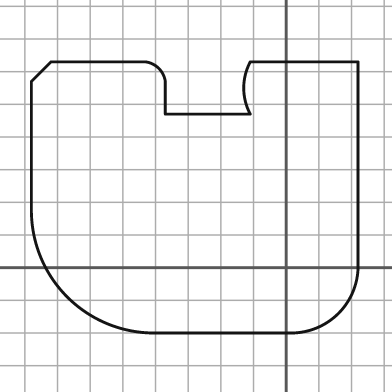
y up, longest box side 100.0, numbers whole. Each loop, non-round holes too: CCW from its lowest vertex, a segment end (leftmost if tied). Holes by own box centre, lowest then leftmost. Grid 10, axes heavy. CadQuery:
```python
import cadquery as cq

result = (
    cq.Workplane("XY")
    .moveTo(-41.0, -20.0)
    .lineTo(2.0, -20.0)
    .threePointArc((16.0, -14.0), (22.0, 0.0))
    .lineTo(22.0, 63.0)
    .lineTo(-11.0, 63.0)
    .threePointArc((-13.0, 55.0), (-11.0, 47.0))
    .lineTo(-37.0, 47.0)
    .lineTo(-37.0, 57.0)
    .threePointArc((-39.0, 61.0), (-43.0, 63.0))
    .lineTo(-72.0, 63.0)
    .lineTo(-78.0, 57.0)
    .lineTo(-78.0, 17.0)
    .threePointArc((-67.0, -9.0), (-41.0, -20.0))
    .close()
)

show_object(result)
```